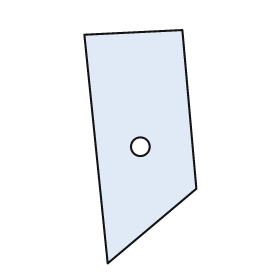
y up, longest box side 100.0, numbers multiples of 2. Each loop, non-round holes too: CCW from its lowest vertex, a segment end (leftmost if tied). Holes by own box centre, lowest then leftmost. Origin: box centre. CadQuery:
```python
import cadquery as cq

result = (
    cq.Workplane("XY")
    .moveTo(-14.0, -50.0)
    .lineTo(24.0, -18.0)
    .lineTo(18.0, 50.0)
    .lineTo(-24.0, 48.0)
    .close()
    .moveTo(0.0, 0.0)
    .circle(4.0)
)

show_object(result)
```